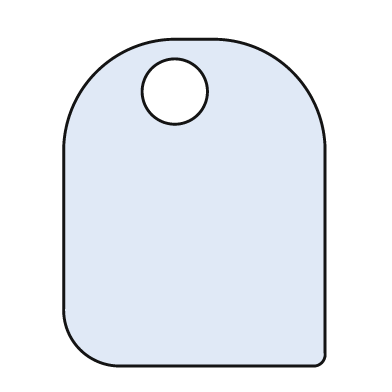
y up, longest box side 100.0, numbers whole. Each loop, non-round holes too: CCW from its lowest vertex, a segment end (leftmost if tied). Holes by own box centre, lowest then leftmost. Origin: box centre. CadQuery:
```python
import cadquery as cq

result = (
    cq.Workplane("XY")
    .moveTo(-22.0, -50.0)
    .lineTo(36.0, -50.0)
    .threePointArc((39.0, -49.0), (40.0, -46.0))
    .lineTo(40.0, 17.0)
    .threePointArc((30.0, 40.0), (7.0, 50.0))
    .lineTo(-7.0, 50.0)
    .threePointArc((-30.0, 40.0), (-40.0, 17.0))
    .lineTo(-40.0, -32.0)
    .threePointArc((-35.0, -45.0), (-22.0, -50.0))
    .close()
    .moveTo(-6.0, 34.0)
    .circle(10.0)
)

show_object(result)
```